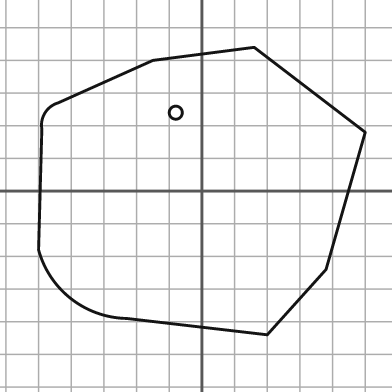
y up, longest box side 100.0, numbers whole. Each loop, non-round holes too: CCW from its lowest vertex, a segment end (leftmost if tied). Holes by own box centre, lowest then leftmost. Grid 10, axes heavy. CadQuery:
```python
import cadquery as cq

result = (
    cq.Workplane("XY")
    .moveTo(20.0, -44.0)
    .lineTo(38.0, -24.0)
    .lineTo(50.0, 18.0)
    .lineTo(16.0, 44.0)
    .lineTo(-15.0, 40.0)
    .lineTo(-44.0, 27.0)
    .threePointArc((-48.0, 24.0), (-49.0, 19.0))
    .lineTo(-50.0, -18.0)
    .threePointArc((-40.0, -33.0), (-23.0, -39.0))
    .close()
    .moveTo(-8.0, 24.0)
    .circle(2.0)
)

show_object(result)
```